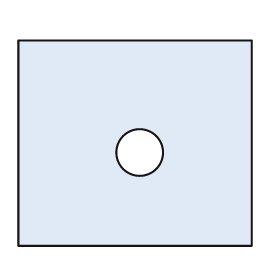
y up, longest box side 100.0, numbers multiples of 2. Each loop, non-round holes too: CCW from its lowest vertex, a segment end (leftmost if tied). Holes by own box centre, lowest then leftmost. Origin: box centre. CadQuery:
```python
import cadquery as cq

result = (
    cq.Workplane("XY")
    .moveTo(-50.0, -44.0)
    .lineTo(50.0, -44.0)
    .lineTo(50.0, 44.0)
    .lineTo(-50.0, 44.0)
    .close()
    .moveTo(2.0, -4.0)
    .circle(10.0)
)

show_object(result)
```